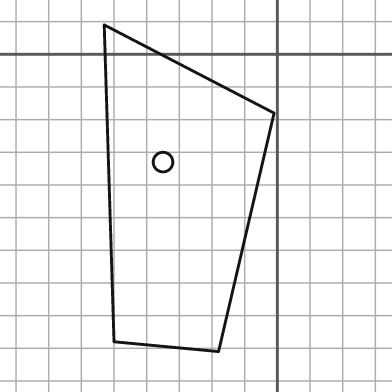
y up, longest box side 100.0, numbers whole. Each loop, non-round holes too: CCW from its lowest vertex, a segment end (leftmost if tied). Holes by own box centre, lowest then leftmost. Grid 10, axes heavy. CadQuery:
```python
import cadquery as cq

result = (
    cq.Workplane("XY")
    .moveTo(-18.0, -91.0)
    .lineTo(-1.0, -18.0)
    .lineTo(-53.0, 9.0)
    .lineTo(-50.0, -88.0)
    .close()
    .moveTo(-35.0, -33.0)
    .circle(3.0)
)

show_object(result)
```